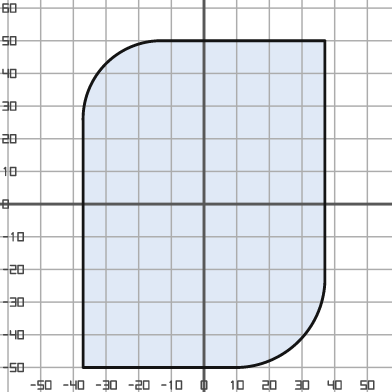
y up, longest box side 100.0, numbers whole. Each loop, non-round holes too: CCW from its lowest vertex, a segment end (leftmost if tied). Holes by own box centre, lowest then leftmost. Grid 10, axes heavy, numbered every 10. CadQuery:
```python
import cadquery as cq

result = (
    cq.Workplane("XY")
    .moveTo(-37.0, -50.0)
    .lineTo(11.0, -50.0)
    .threePointArc((29.0, -42.0), (37.0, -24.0))
    .lineTo(37.0, 50.0)
    .lineTo(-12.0, 50.0)
    .threePointArc((-30.0, 43.0), (-37.0, 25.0))
    .close()
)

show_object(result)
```